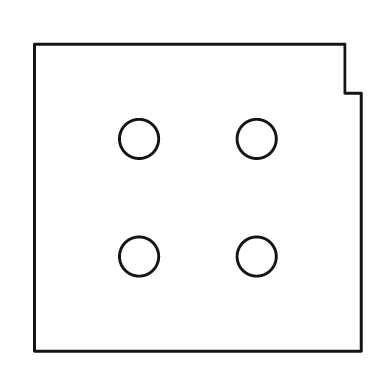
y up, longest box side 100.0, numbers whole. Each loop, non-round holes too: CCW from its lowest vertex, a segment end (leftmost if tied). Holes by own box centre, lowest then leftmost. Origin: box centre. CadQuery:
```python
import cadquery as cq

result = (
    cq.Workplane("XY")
    .moveTo(-50.0, -47.0)
    .lineTo(50.0, -47.0)
    .lineTo(50.0, 32.0)
    .lineTo(45.0, 32.0)
    .lineTo(45.0, 47.0)
    .lineTo(-50.0, 47.0)
    .close()
    .moveTo(-18.0, -18.0)
    .circle(6.0)
    .moveTo(18.0, -18.0)
    .circle(6.0)
    .moveTo(-18.0, 18.0)
    .circle(6.0)
    .moveTo(18.0, 18.0)
    .circle(6.0)
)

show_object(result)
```